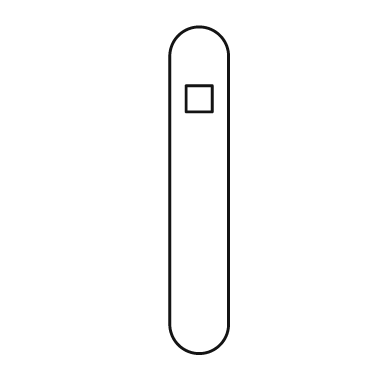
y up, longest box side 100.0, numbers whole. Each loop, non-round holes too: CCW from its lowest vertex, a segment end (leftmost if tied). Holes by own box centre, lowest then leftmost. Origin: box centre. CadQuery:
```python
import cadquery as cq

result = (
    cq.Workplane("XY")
    .moveTo(-9.0, -41.0)
    .threePointArc((0.0, -50.0), (9.0, -41.0))
    .lineTo(9.0, 41.0)
    .threePointArc((0.0, 50.0), (-9.0, 41.0))
    .close()
    .moveTo(-4.0, 24.0)
    .lineTo(4.0, 24.0)
    .lineTo(4.0, 32.0)
    .lineTo(-4.0, 32.0)
    .close()
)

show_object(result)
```